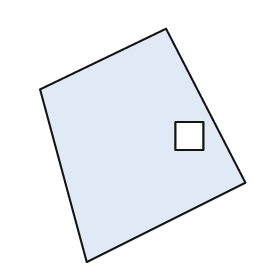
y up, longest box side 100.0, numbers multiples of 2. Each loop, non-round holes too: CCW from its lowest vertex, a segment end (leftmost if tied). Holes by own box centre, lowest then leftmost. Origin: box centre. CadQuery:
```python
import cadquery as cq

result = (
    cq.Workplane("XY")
    .moveTo(-24.0, -50.0)
    .lineTo(44.0, -16.0)
    .lineTo(10.0, 50.0)
    .lineTo(-44.0, 24.0)
    .close()
    .moveTo(14.0, -2.0)
    .lineTo(26.0, -2.0)
    .lineTo(26.0, 10.0)
    .lineTo(14.0, 10.0)
    .close()
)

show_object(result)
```